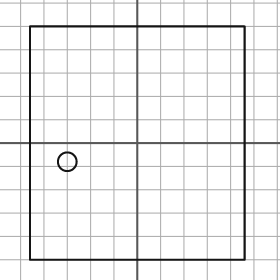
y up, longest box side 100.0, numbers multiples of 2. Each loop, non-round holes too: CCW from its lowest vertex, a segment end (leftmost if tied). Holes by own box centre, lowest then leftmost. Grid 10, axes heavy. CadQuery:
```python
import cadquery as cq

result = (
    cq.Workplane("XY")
    .moveTo(-46.0, -50.0)
    .lineTo(46.0, -50.0)
    .lineTo(46.0, 50.0)
    .lineTo(-46.0, 50.0)
    .close()
    .moveTo(-30.0, -8.0)
    .circle(4.0)
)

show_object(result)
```